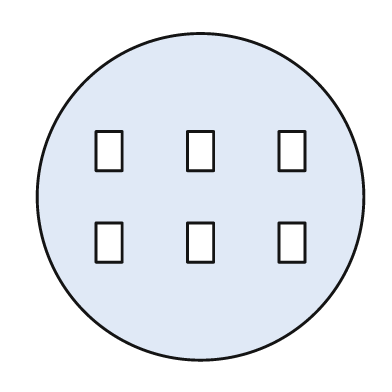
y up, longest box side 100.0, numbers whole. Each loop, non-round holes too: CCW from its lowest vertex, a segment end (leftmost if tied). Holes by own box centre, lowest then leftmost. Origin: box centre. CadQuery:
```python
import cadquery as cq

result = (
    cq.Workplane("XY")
    .moveTo(0.0, 0.0)
    .circle(50.0)
    .moveTo(-32.0, -20.0)
    .lineTo(-24.0, -20.0)
    .lineTo(-24.0, -8.0)
    .lineTo(-32.0, -8.0)
    .close()
    .moveTo(-4.0, -20.0)
    .lineTo(4.0, -20.0)
    .lineTo(4.0, -8.0)
    .lineTo(-4.0, -8.0)
    .close()
    .moveTo(24.0, -20.0)
    .lineTo(32.0, -20.0)
    .lineTo(32.0, -8.0)
    .lineTo(24.0, -8.0)
    .close()
    .moveTo(-32.0, 8.0)
    .lineTo(-24.0, 8.0)
    .lineTo(-24.0, 20.0)
    .lineTo(-32.0, 20.0)
    .close()
    .moveTo(-4.0, 8.0)
    .lineTo(4.0, 8.0)
    .lineTo(4.0, 20.0)
    .lineTo(-4.0, 20.0)
    .close()
    .moveTo(24.0, 8.0)
    .lineTo(32.0, 8.0)
    .lineTo(32.0, 20.0)
    .lineTo(24.0, 20.0)
    .close()
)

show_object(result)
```